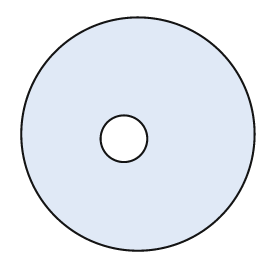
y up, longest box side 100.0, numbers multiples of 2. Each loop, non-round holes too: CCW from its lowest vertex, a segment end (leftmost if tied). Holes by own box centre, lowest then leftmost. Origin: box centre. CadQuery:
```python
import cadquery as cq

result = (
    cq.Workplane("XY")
    .moveTo(0.0, 0.0)
    .circle(50.0)
    .moveTo(-6.0, -2.0)
    .circle(10.0)
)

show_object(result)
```